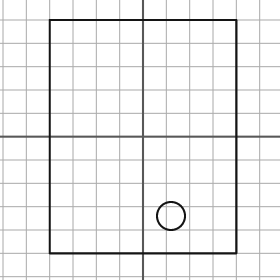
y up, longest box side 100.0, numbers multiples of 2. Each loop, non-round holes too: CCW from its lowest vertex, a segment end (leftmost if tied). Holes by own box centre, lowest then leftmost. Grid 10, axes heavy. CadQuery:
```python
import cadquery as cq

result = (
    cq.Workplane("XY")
    .moveTo(-40.0, -50.0)
    .lineTo(40.0, -50.0)
    .lineTo(40.0, 50.0)
    .lineTo(-40.0, 50.0)
    .close()
    .moveTo(12.0, -34.0)
    .circle(6.0)
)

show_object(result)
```